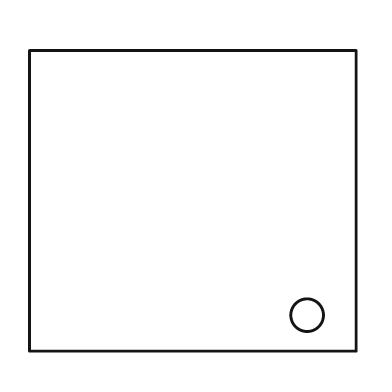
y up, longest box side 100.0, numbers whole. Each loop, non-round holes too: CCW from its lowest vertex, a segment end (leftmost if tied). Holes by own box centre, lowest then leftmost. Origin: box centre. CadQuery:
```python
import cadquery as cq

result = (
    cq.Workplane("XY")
    .moveTo(-50.0, -46.0)
    .lineTo(50.0, -46.0)
    .lineTo(50.0, 46.0)
    .lineTo(-50.0, 46.0)
    .close()
    .moveTo(35.0, -35.0)
    .circle(5.0)
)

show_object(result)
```